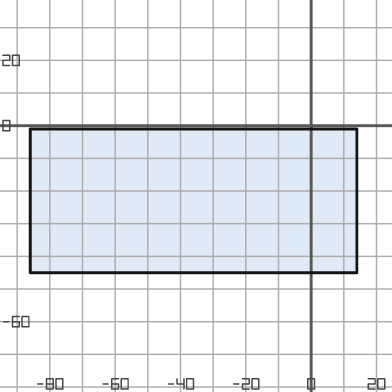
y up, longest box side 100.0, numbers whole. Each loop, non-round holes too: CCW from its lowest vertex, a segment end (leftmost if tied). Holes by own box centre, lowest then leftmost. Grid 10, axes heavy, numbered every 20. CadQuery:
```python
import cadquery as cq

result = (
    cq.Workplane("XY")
    .moveTo(-86.0, -45.0)
    .lineTo(14.0, -45.0)
    .lineTo(14.0, -1.0)
    .lineTo(-86.0, -1.0)
    .close()
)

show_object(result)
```